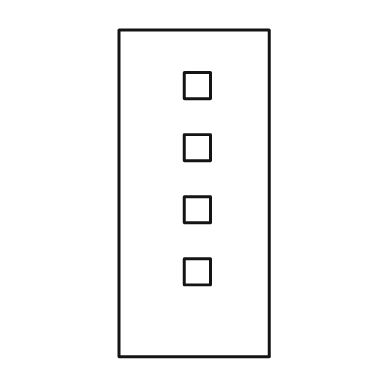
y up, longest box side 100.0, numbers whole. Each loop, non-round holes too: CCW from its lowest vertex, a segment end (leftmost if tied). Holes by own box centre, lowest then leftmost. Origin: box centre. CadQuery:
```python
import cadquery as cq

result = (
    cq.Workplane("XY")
    .moveTo(-23.0, -50.0)
    .lineTo(23.0, -50.0)
    .lineTo(23.0, 50.0)
    .lineTo(-23.0, 50.0)
    .close()
    .moveTo(-3.0, -28.0)
    .lineTo(5.0, -28.0)
    .lineTo(5.0, -20.0)
    .lineTo(-3.0, -20.0)
    .close()
    .moveTo(-3.0, -9.0)
    .lineTo(5.0, -9.0)
    .lineTo(5.0, -1.0)
    .lineTo(-3.0, -1.0)
    .close()
    .moveTo(-3.0, 10.0)
    .lineTo(5.0, 10.0)
    .lineTo(5.0, 18.0)
    .lineTo(-3.0, 18.0)
    .close()
    .moveTo(-3.0, 29.0)
    .lineTo(5.0, 29.0)
    .lineTo(5.0, 37.0)
    .lineTo(-3.0, 37.0)
    .close()
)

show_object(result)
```